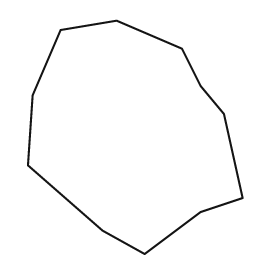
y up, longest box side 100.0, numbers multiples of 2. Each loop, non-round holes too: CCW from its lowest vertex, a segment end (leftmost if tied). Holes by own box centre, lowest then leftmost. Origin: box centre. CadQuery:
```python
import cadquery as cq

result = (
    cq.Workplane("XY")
    .moveTo(4.0, -50.0)
    .lineTo(28.0, -32.0)
    .lineTo(46.0, -26.0)
    .lineTo(38.0, 10.0)
    .lineTo(28.0, 22.0)
    .lineTo(20.0, 38.0)
    .lineTo(-8.0, 50.0)
    .lineTo(-32.0, 46.0)
    .lineTo(-44.0, 18.0)
    .lineTo(-46.0, -12.0)
    .lineTo(-14.0, -40.0)
    .close()
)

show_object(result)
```